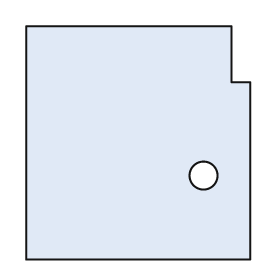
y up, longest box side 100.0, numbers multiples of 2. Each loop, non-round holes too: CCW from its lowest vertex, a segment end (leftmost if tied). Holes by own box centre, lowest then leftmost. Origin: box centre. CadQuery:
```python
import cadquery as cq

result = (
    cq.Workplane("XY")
    .moveTo(-48.0, -50.0)
    .lineTo(48.0, -50.0)
    .lineTo(48.0, 26.0)
    .lineTo(40.0, 26.0)
    .lineTo(40.0, 50.0)
    .lineTo(-48.0, 50.0)
    .close()
    .moveTo(28.0, -14.0)
    .circle(6.0)
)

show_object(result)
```